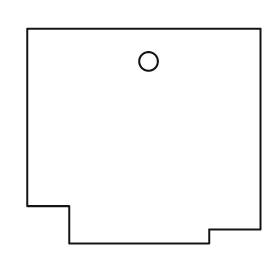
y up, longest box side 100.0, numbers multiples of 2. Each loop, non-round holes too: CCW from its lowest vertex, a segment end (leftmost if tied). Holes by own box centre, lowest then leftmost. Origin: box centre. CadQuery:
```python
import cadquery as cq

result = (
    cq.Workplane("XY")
    .moveTo(-32.0, -46.0)
    .lineTo(28.0, -46.0)
    .lineTo(28.0, -40.0)
    .lineTo(50.0, -40.0)
    .lineTo(50.0, 46.0)
    .lineTo(-50.0, 46.0)
    .lineTo(-50.0, -30.0)
    .lineTo(-32.0, -30.0)
    .close()
    .moveTo(2.0, 32.0)
    .circle(4.0)
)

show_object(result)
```